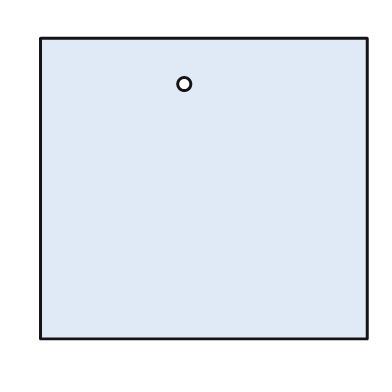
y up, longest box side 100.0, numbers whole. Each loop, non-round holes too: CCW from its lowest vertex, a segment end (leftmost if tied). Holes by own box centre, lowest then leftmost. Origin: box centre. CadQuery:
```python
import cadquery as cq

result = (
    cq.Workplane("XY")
    .moveTo(-50.0, -46.0)
    .lineTo(50.0, -46.0)
    .lineTo(50.0, 46.0)
    .lineTo(-50.0, 46.0)
    .close()
    .moveTo(-6.0, 32.0)
    .circle(2.0)
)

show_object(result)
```